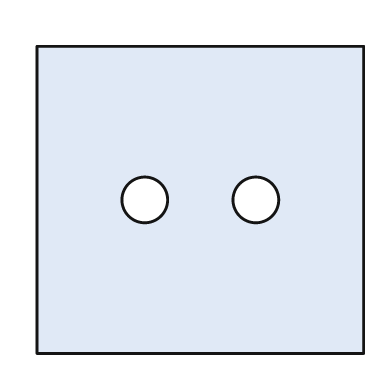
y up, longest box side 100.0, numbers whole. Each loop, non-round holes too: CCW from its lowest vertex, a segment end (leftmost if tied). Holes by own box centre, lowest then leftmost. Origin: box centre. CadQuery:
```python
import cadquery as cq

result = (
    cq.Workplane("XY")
    .moveTo(-50.0, -47.0)
    .lineTo(50.0, -47.0)
    .lineTo(50.0, 47.0)
    .lineTo(-50.0, 47.0)
    .close()
    .moveTo(-17.0, 0.0)
    .circle(7.0)
    .moveTo(17.0, 0.0)
    .circle(7.0)
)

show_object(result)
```